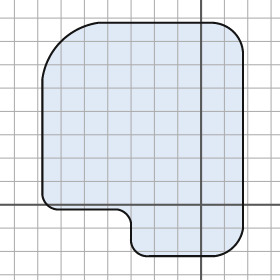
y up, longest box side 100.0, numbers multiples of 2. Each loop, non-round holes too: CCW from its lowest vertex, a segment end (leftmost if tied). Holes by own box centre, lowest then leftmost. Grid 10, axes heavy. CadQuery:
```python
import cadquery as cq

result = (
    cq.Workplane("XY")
    .moveTo(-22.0, -22.0)
    .lineTo(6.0, -22.0)
    .threePointArc((14.0, -18.0), (18.0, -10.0))
    .lineTo(18.0, 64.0)
    .threePointArc((14.0, 74.0), (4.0, 78.0))
    .lineTo(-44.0, 78.0)
    .threePointArc((-60.0, 70.0), (-68.0, 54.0))
    .lineTo(-68.0, 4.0)
    .threePointArc((-66.0, 0.0), (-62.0, -2.0))
    .lineTo(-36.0, -2.0)
    .threePointArc((-32.0, -4.0), (-30.0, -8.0))
    .lineTo(-30.0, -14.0)
    .threePointArc((-28.0, -20.0), (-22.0, -22.0))
    .close()
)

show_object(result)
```